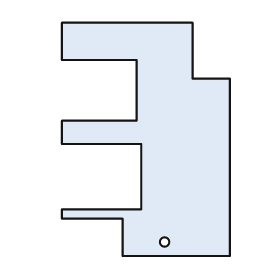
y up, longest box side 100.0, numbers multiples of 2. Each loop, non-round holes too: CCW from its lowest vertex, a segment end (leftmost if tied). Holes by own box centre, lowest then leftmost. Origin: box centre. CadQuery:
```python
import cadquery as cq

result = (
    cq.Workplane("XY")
    .moveTo(-10.0, -50.0)
    .lineTo(36.0, -50.0)
    .lineTo(36.0, 26.0)
    .lineTo(20.0, 26.0)
    .lineTo(20.0, 50.0)
    .lineTo(-36.0, 50.0)
    .lineTo(-36.0, 34.0)
    .lineTo(-4.0, 34.0)
    .lineTo(-4.0, 8.0)
    .lineTo(-36.0, 8.0)
    .lineTo(-36.0, -2.0)
    .lineTo(-2.0, -2.0)
    .lineTo(-2.0, -30.0)
    .lineTo(-36.0, -30.0)
    .lineTo(-36.0, -34.0)
    .lineTo(-10.0, -34.0)
    .close()
    .moveTo(8.0, -44.0)
    .circle(2.0)
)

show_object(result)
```